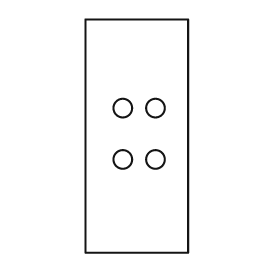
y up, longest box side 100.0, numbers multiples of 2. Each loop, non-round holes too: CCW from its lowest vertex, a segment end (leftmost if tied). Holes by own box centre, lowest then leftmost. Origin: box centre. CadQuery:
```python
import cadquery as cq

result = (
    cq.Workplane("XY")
    .moveTo(-22.0, -50.0)
    .lineTo(22.0, -50.0)
    .lineTo(22.0, 50.0)
    .lineTo(-22.0, 50.0)
    .close()
    .moveTo(-6.0, -10.0)
    .circle(4.0)
    .moveTo(8.0, -10.0)
    .circle(4.0)
    .moveTo(-6.0, 12.0)
    .circle(4.0)
    .moveTo(8.0, 12.0)
    .circle(4.0)
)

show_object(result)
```